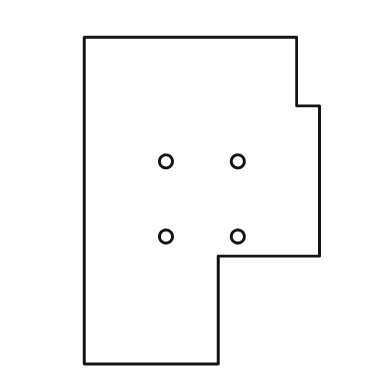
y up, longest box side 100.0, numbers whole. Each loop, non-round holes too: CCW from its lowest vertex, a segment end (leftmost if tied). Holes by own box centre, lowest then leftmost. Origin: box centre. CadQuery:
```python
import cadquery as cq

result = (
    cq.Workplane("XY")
    .moveTo(-36.0, -50.0)
    .lineTo(5.0, -50.0)
    .lineTo(5.0, -17.0)
    .lineTo(36.0, -17.0)
    .lineTo(36.0, 29.0)
    .lineTo(29.0, 29.0)
    .lineTo(29.0, 50.0)
    .lineTo(-36.0, 50.0)
    .close()
    .moveTo(-11.0, -11.0)
    .circle(2.0)
    .moveTo(11.0, -11.0)
    .circle(2.0)
    .moveTo(-11.0, 12.0)
    .circle(2.0)
    .moveTo(11.0, 12.0)
    .circle(2.0)
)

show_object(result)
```